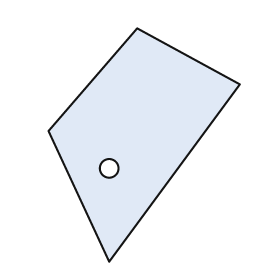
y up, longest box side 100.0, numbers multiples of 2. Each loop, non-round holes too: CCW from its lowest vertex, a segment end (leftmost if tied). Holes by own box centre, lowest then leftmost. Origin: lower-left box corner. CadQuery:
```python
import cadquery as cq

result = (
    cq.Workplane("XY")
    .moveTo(26.0, 0.0)
    .lineTo(82.0, 76.0)
    .lineTo(38.0, 100.0)
    .lineTo(0.0, 56.0)
    .close()
    .moveTo(26.0, 40.0)
    .circle(4.0)
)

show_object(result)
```